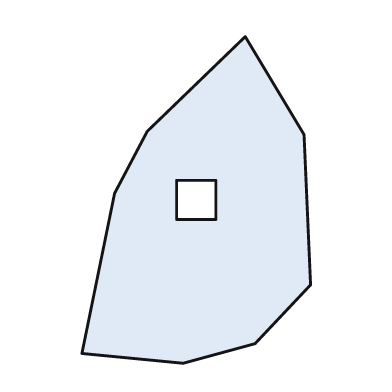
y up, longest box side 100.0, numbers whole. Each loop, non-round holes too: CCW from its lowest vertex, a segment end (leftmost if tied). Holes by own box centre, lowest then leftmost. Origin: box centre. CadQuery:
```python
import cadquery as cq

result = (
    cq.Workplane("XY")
    .moveTo(-4.0, -50.0)
    .lineTo(18.0, -44.0)
    .lineTo(35.0, -26.0)
    .lineTo(33.0, 20.0)
    .lineTo(15.0, 50.0)
    .lineTo(-15.0, 21.0)
    .lineTo(-25.0, 2.0)
    .lineTo(-35.0, -47.0)
    .close()
    .moveTo(-6.0, -6.0)
    .lineTo(6.0, -6.0)
    .lineTo(6.0, 6.0)
    .lineTo(-6.0, 6.0)
    .close()
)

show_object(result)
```